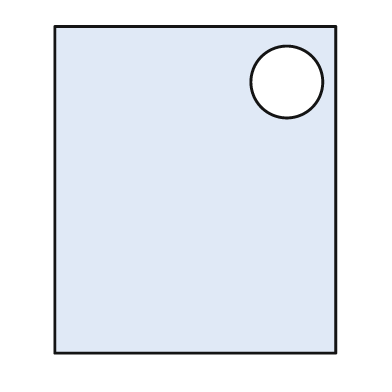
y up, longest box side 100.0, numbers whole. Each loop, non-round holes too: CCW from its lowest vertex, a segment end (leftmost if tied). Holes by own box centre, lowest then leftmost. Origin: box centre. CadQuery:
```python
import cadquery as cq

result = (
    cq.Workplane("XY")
    .moveTo(-43.0, -50.0)
    .lineTo(43.0, -50.0)
    .lineTo(43.0, 50.0)
    .lineTo(-43.0, 50.0)
    .close()
    .moveTo(28.0, 33.0)
    .circle(11.0)
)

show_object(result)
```